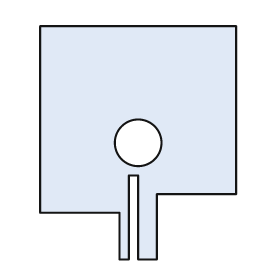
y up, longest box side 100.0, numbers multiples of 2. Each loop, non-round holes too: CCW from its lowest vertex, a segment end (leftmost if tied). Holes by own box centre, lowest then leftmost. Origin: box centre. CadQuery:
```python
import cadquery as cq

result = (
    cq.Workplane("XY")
    .moveTo(-8.0, -50.0)
    .lineTo(-4.0, -50.0)
    .lineTo(-4.0, -14.0)
    .lineTo(0.0, -14.0)
    .lineTo(0.0, -50.0)
    .lineTo(8.0, -50.0)
    .lineTo(8.0, -22.0)
    .lineTo(42.0, -22.0)
    .lineTo(42.0, 50.0)
    .lineTo(-42.0, 50.0)
    .lineTo(-42.0, -30.0)
    .lineTo(-8.0, -30.0)
    .close()
    .moveTo(0.0, 0.0)
    .circle(10.0)
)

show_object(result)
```